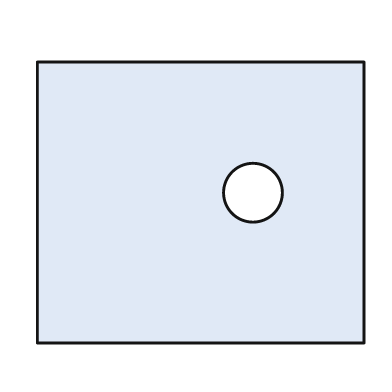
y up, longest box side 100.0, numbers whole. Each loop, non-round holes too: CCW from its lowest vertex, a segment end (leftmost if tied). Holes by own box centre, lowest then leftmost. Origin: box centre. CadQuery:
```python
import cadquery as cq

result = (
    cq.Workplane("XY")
    .moveTo(-50.0, -43.0)
    .lineTo(50.0, -43.0)
    .lineTo(50.0, 43.0)
    .lineTo(-50.0, 43.0)
    .close()
    .moveTo(16.0, 3.0)
    .circle(9.0)
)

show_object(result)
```